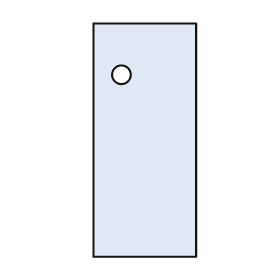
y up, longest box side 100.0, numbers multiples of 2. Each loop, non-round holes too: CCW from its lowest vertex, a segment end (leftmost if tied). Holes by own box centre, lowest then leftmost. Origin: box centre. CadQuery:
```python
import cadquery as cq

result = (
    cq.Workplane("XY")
    .moveTo(-22.0, -50.0)
    .lineTo(22.0, -50.0)
    .lineTo(22.0, 50.0)
    .lineTo(-22.0, 50.0)
    .close()
    .moveTo(-10.0, 28.0)
    .circle(4.0)
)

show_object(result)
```